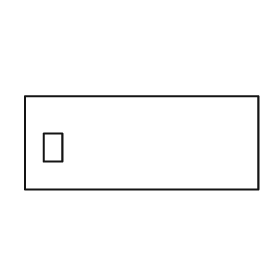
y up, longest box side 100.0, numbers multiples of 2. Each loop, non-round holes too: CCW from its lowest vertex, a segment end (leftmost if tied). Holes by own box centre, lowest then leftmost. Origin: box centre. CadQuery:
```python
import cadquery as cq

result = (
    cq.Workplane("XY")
    .moveTo(-50.0, -20.0)
    .lineTo(50.0, -20.0)
    .lineTo(50.0, 20.0)
    .lineTo(-50.0, 20.0)
    .close()
    .moveTo(-42.0, -8.0)
    .lineTo(-34.0, -8.0)
    .lineTo(-34.0, 4.0)
    .lineTo(-42.0, 4.0)
    .close()
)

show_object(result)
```